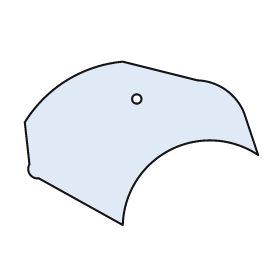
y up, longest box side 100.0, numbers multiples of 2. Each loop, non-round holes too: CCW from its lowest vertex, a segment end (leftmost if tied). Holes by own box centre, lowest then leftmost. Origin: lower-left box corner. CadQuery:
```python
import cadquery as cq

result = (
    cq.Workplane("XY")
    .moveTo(42.0, 0.0)
    .threePointArc((62.0, 32.0), (100.0, 30.0))
    .lineTo(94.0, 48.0)
    .threePointArc((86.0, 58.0), (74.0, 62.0))
    .lineTo(42.0, 70.0)
    .threePointArc((18.0, 62.0), (0.0, 44.0))
    .lineTo(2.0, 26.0)
    .threePointArc((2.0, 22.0), (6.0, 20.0))
    .close()
    .moveTo(48.0, 54.0)
    .circle(2.0)
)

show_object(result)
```